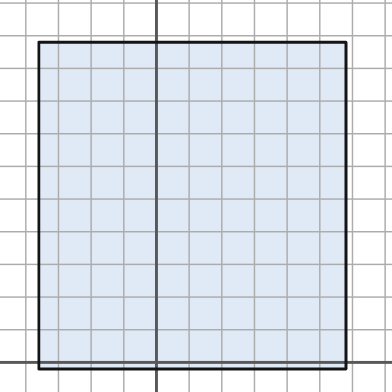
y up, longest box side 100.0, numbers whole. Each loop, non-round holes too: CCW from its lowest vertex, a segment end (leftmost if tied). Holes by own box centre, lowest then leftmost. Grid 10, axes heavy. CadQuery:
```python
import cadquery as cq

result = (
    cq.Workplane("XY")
    .moveTo(-36.0, -2.0)
    .lineTo(58.0, -2.0)
    .lineTo(58.0, 98.0)
    .lineTo(-36.0, 98.0)
    .close()
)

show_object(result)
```